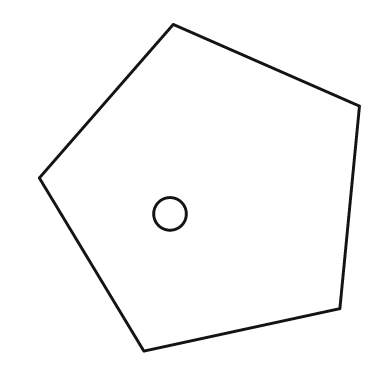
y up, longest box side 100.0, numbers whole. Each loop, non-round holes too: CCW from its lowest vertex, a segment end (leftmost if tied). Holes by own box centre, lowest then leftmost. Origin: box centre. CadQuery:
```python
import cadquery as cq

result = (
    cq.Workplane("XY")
    .moveTo(-17.0, -50.0)
    .lineTo(43.0, -37.0)
    .lineTo(49.0, 25.0)
    .lineTo(-8.0, 50.0)
    .lineTo(-49.0, 3.0)
    .close()
    .moveTo(-9.0, -8.0)
    .circle(5.0)
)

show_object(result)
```